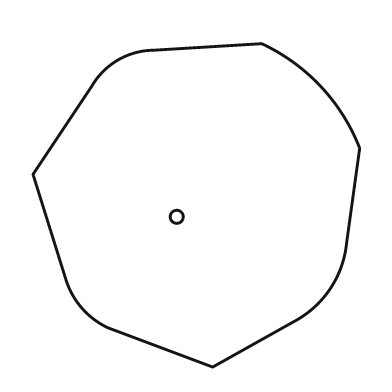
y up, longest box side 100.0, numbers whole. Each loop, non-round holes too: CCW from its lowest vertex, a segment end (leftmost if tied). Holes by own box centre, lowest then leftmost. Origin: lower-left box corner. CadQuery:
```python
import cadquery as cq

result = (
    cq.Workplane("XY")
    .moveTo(55.0, 0.0)
    .lineTo(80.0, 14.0)
    .threePointArc((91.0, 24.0), (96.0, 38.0))
    .lineTo(100.0, 67.0)
    .threePointArc((88.0, 86.0), (70.0, 99.0))
    .lineTo(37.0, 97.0)
    .threePointArc((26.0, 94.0), (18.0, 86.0))
    .lineTo(0.0, 59.0)
    .lineTo(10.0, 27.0)
    .threePointArc((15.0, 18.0), (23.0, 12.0))
    .close()
    .moveTo(44.0, 46.0)
    .circle(2.0)
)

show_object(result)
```